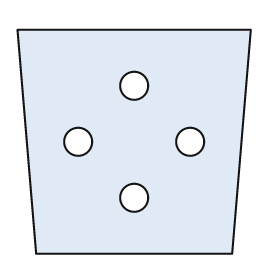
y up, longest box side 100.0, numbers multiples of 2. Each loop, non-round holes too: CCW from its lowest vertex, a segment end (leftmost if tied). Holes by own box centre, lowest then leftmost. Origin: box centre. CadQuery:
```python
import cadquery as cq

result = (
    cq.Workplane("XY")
    .moveTo(-42.0, -48.0)
    .lineTo(42.0, -48.0)
    .lineTo(50.0, 48.0)
    .lineTo(-50.0, 48.0)
    .close()
    .moveTo(0.0, -24.0)
    .circle(6.0)
    .moveTo(-24.0, 0.0)
    .circle(6.0)
    .moveTo(24.0, 0.0)
    .circle(6.0)
    .moveTo(0.0, 24.0)
    .circle(6.0)
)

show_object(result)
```